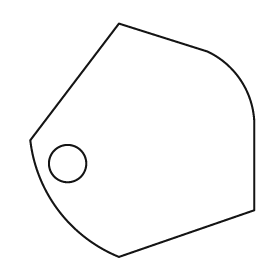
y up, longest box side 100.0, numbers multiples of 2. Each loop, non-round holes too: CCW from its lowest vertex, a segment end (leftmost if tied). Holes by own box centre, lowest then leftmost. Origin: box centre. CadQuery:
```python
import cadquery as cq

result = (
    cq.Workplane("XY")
    .moveTo(-10.0, -50.0)
    .lineTo(48.0, -30.0)
    .lineTo(48.0, 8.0)
    .threePointArc((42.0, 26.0), (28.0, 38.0))
    .lineTo(-10.0, 50.0)
    .lineTo(-48.0, 0.0)
    .threePointArc((-36.0, -30.0), (-10.0, -50.0))
    .close()
    .moveTo(-32.0, -10.0)
    .circle(8.0)
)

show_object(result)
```